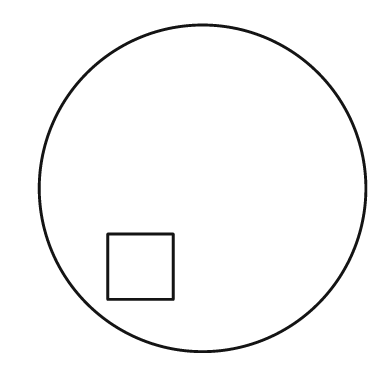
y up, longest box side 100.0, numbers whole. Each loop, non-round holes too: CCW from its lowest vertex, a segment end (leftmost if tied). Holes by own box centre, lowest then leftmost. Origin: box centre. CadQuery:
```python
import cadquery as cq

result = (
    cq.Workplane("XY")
    .moveTo(0.0, 0.0)
    .circle(50.0)
    .moveTo(-29.0, -34.0)
    .lineTo(-9.0, -34.0)
    .lineTo(-9.0, -14.0)
    .lineTo(-29.0, -14.0)
    .close()
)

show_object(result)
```